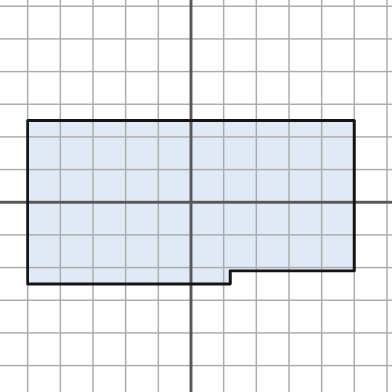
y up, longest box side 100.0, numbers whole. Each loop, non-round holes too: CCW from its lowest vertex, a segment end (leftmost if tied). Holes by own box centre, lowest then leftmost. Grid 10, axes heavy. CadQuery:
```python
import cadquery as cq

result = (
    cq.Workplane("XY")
    .moveTo(-50.0, -25.0)
    .lineTo(12.0, -25.0)
    .lineTo(12.0, -21.0)
    .lineTo(50.0, -21.0)
    .lineTo(50.0, 25.0)
    .lineTo(-50.0, 25.0)
    .close()
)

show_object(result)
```